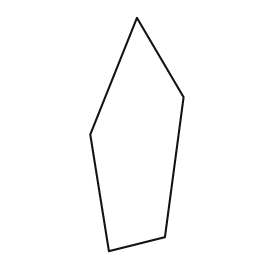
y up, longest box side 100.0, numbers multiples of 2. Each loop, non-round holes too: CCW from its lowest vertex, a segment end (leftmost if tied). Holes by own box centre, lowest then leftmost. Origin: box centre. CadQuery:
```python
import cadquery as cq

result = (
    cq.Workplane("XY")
    .moveTo(-12.0, -50.0)
    .lineTo(12.0, -44.0)
    .lineTo(20.0, 16.0)
    .lineTo(0.0, 50.0)
    .lineTo(-20.0, 0.0)
    .close()
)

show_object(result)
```